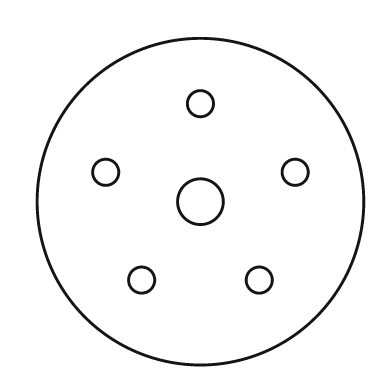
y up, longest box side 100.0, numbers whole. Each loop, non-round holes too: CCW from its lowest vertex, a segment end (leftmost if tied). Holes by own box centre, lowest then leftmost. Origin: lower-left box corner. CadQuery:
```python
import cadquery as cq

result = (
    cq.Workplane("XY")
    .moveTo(50.0, 50.0)
    .circle(50.0)
    .moveTo(32.0, 26.0)
    .circle(4.0)
    .moveTo(68.0, 26.0)
    .circle(4.0)
    .moveTo(50.0, 50.0)
    .circle(7.0)
    .moveTo(21.0, 59.0)
    .circle(4.0)
    .moveTo(79.0, 59.0)
    .circle(4.0)
    .moveTo(50.0, 80.0)
    .circle(4.0)
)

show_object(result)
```